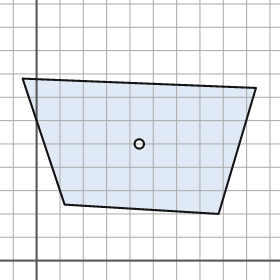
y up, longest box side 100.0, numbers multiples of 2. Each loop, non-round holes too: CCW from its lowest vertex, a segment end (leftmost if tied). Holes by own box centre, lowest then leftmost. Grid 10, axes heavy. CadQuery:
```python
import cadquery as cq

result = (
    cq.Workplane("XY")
    .moveTo(78.0, 20.0)
    .lineTo(94.0, 74.0)
    .lineTo(-6.0, 78.0)
    .lineTo(12.0, 24.0)
    .close()
    .moveTo(44.0, 50.0)
    .circle(2.0)
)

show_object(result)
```